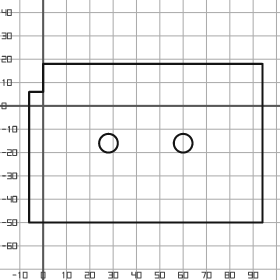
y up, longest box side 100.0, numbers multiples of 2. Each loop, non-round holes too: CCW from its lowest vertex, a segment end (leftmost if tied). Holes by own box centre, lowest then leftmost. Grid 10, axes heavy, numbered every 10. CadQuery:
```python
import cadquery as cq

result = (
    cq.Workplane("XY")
    .moveTo(-6.0, -50.0)
    .lineTo(94.0, -50.0)
    .lineTo(94.0, 18.0)
    .lineTo(0.0, 18.0)
    .lineTo(0.0, 6.0)
    .lineTo(-6.0, 6.0)
    .close()
    .moveTo(28.0, -16.0)
    .circle(4.0)
    .moveTo(60.0, -16.0)
    .circle(4.0)
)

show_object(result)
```